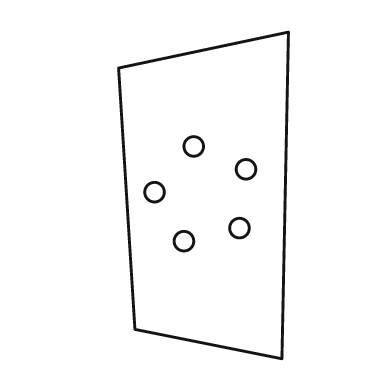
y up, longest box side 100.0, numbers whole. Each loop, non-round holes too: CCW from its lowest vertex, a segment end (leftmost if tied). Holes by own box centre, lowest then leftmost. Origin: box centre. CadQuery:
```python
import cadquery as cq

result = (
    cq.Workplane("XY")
    .moveTo(24.0, -50.0)
    .lineTo(26.0, 50.0)
    .lineTo(-26.0, 39.0)
    .lineTo(-21.0, -41.0)
    .close()
    .moveTo(-6.0, -14.0)
    .circle(3.0)
    .moveTo(11.0, -10.0)
    .circle(3.0)
    .moveTo(-15.0, 1.0)
    .circle(3.0)
    .moveTo(13.0, 8.0)
    .circle(3.0)
    .moveTo(-3.0, 15.0)
    .circle(3.0)
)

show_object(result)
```